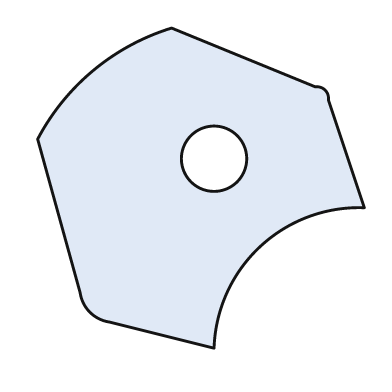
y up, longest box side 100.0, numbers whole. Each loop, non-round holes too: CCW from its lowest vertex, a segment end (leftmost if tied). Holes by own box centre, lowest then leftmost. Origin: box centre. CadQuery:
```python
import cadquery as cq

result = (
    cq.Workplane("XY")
    .moveTo(4.0, -49.0)
    .threePointArc((18.0, -18.0), (50.0, -6.0))
    .lineTo(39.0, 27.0)
    .threePointArc((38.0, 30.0), (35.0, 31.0))
    .lineTo(-9.0, 49.0)
    .threePointArc((-33.0, 36.0), (-50.0, 15.0))
    .lineTo(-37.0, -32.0)
    .threePointArc((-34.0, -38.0), (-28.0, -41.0))
    .close()
    .moveTo(4.0, 9.0)
    .circle(10.0)
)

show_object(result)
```